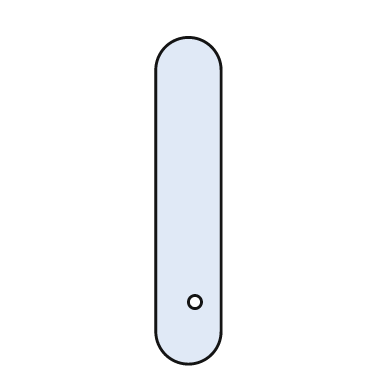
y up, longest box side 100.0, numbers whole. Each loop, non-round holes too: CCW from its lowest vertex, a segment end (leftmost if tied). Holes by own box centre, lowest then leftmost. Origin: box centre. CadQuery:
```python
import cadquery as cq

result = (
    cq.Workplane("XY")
    .moveTo(-10.0, -40.0)
    .threePointArc((0.0, -50.0), (10.0, -40.0))
    .lineTo(10.0, 40.0)
    .threePointArc((0.0, 50.0), (-10.0, 40.0))
    .close()
    .moveTo(2.0, -31.0)
    .circle(2.0)
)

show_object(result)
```